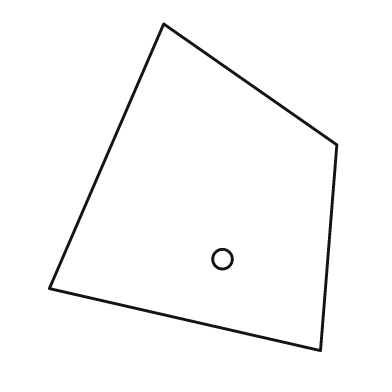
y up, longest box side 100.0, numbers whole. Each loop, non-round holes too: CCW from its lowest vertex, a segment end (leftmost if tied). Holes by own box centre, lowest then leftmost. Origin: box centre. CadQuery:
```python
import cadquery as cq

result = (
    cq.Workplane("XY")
    .moveTo(39.0, -50.0)
    .lineTo(44.0, 13.0)
    .lineTo(-9.0, 50.0)
    .lineTo(-44.0, -31.0)
    .close()
    .moveTo(9.0, -22.0)
    .circle(3.0)
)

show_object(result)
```